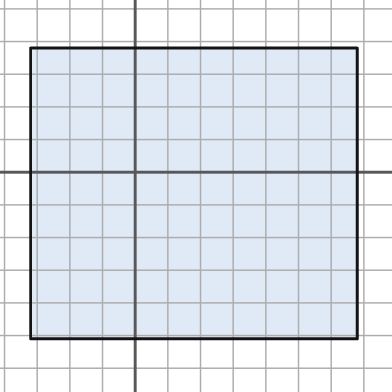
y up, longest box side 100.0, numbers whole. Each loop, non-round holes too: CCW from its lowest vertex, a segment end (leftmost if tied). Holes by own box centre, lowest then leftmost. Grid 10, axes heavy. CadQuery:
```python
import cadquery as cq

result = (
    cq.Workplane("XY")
    .moveTo(-32.0, -51.0)
    .lineTo(68.0, -51.0)
    .lineTo(68.0, 38.0)
    .lineTo(-32.0, 38.0)
    .close()
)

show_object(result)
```